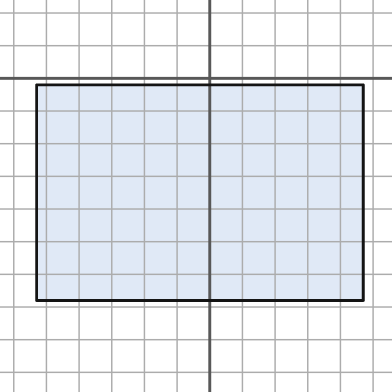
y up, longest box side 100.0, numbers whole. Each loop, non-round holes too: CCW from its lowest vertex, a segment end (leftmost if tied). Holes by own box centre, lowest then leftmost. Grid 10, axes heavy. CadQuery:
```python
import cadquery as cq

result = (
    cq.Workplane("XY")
    .moveTo(-53.0, -68.0)
    .lineTo(47.0, -68.0)
    .lineTo(47.0, -2.0)
    .lineTo(-53.0, -2.0)
    .close()
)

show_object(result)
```